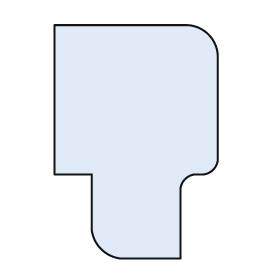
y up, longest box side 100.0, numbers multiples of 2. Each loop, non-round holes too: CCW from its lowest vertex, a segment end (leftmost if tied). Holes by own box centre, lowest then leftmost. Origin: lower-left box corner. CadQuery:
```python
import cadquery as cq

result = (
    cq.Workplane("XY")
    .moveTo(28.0, 0.0)
    .lineTo(54.0, 0.0)
    .lineTo(54.0, 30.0)
    .threePointArc((56.0, 34.0), (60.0, 36.0))
    .lineTo(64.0, 36.0)
    .threePointArc((68.0, 38.0), (70.0, 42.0))
    .lineTo(70.0, 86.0)
    .threePointArc((66.0, 96.0), (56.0, 100.0))
    .lineTo(0.0, 100.0)
    .lineTo(0.0, 36.0)
    .lineTo(16.0, 36.0)
    .lineTo(16.0, 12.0)
    .threePointArc((20.0, 4.0), (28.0, 0.0))
    .close()
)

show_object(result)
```